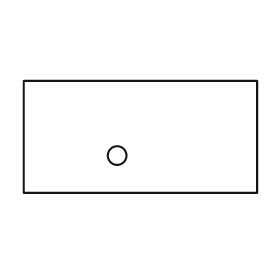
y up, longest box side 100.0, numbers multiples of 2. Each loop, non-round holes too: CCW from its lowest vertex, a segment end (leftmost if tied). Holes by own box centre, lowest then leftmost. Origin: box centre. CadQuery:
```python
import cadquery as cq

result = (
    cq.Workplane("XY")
    .moveTo(-50.0, -24.0)
    .lineTo(50.0, -24.0)
    .lineTo(50.0, 24.0)
    .lineTo(-50.0, 24.0)
    .close()
    .moveTo(-10.0, -8.0)
    .circle(4.0)
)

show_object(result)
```